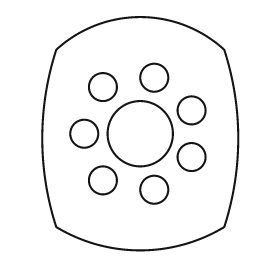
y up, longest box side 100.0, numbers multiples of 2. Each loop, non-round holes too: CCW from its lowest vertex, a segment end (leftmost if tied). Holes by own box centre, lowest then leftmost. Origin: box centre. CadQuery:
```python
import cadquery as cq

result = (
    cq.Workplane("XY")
    .moveTo(-36.0, -40.0)
    .threePointArc((0.0, -50.0), (36.0, -40.0))
    .threePointArc((42.0, -2.0), (36.0, 36.0))
    .threePointArc((0.0, 50.0), (-36.0, 36.0))
    .threePointArc((-42.0, -2.0), (-36.0, -40.0))
    .close()
    .moveTo(6.0, -24.0)
    .circle(6.0)
    .moveTo(-16.0, -20.0)
    .circle(6.0)
    .moveTo(22.0, -10.0)
    .circle(6.0)
    .moveTo(-24.0, 0.0)
    .circle(6.0)
    .moveTo(0.0, 0.0)
    .circle(14.0)
    .moveTo(22.0, 10.0)
    .circle(6.0)
    .moveTo(-16.0, 20.0)
    .circle(6.0)
    .moveTo(6.0, 24.0)
    .circle(6.0)
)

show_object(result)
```